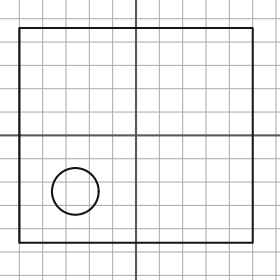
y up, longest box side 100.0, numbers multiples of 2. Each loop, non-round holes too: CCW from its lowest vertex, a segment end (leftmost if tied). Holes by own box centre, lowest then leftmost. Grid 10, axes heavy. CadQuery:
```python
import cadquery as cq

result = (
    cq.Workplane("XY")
    .moveTo(-50.0, -46.0)
    .lineTo(50.0, -46.0)
    .lineTo(50.0, 46.0)
    .lineTo(-50.0, 46.0)
    .close()
    .moveTo(-26.0, -24.0)
    .circle(10.0)
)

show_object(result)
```